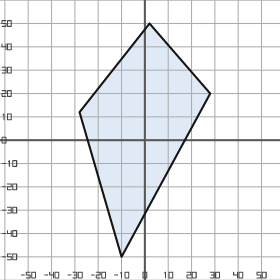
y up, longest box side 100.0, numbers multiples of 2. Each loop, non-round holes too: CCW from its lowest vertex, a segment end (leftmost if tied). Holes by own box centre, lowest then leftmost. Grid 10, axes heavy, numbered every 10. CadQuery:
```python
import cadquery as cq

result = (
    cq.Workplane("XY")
    .moveTo(-10.0, -50.0)
    .lineTo(28.0, 20.0)
    .lineTo(2.0, 50.0)
    .lineTo(-28.0, 12.0)
    .close()
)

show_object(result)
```